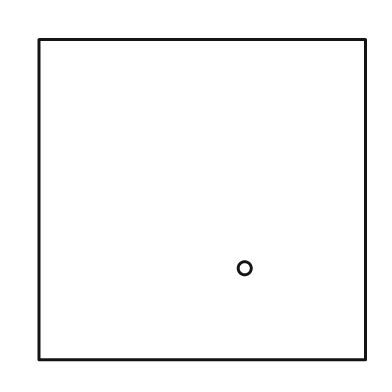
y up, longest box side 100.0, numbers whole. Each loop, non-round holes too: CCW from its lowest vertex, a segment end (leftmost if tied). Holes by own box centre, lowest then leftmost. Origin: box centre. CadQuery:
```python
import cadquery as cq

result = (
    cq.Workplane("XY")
    .moveTo(-50.0, -49.0)
    .lineTo(50.0, -49.0)
    .lineTo(50.0, 49.0)
    .lineTo(-50.0, 49.0)
    .close()
    .moveTo(13.0, -21.0)
    .circle(2.0)
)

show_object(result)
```